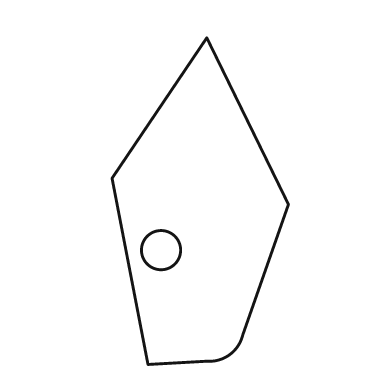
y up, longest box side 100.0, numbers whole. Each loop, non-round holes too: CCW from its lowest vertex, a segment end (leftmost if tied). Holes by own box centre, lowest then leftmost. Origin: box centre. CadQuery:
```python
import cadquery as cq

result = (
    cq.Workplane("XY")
    .moveTo(-16.0, -50.0)
    .lineTo(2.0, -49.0)
    .threePointArc((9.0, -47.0), (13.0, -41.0))
    .lineTo(27.0, -1.0)
    .lineTo(2.0, 50.0)
    .lineTo(-27.0, 7.0)
    .close()
    .moveTo(-12.0, -15.0)
    .circle(6.0)
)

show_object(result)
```